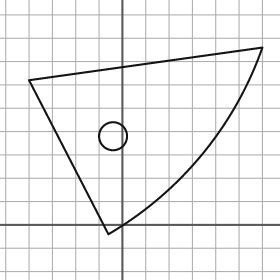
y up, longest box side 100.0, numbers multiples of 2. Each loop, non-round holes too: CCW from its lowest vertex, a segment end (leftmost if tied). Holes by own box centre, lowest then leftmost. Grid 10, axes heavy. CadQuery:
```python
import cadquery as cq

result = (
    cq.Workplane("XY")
    .moveTo(-6.0, -4.0)
    .threePointArc((34.0, 30.0), (60.0, 76.0))
    .lineTo(-40.0, 62.0)
    .close()
    .moveTo(-4.0, 38.0)
    .circle(6.0)
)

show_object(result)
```